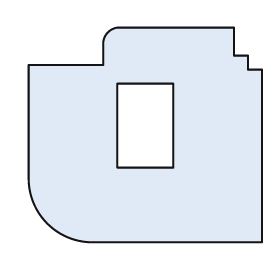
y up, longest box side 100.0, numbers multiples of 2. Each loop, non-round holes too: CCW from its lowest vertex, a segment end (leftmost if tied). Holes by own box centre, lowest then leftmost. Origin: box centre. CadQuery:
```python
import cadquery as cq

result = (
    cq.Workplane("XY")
    .moveTo(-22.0, -46.0)
    .lineTo(50.0, -46.0)
    .lineTo(50.0, 28.0)
    .lineTo(44.0, 28.0)
    .lineTo(44.0, 34.0)
    .lineTo(38.0, 34.0)
    .lineTo(38.0, 46.0)
    .lineTo(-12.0, 46.0)
    .threePointArc((-16.0, 44.0), (-18.0, 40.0))
    .lineTo(-18.0, 30.0)
    .lineTo(-50.0, 30.0)
    .lineTo(-50.0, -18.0)
    .threePointArc((-42.0, -38.0), (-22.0, -46.0))
    .close()
    .moveTo(-12.0, -14.0)
    .lineTo(12.0, -14.0)
    .lineTo(12.0, 22.0)
    .lineTo(-12.0, 22.0)
    .close()
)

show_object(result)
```